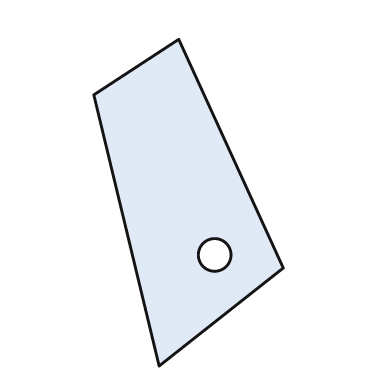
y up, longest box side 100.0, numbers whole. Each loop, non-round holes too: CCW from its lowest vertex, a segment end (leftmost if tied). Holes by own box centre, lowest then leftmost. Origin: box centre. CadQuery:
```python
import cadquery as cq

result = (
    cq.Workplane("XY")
    .moveTo(-9.0, -50.0)
    .lineTo(29.0, -20.0)
    .lineTo(-3.0, 50.0)
    .lineTo(-29.0, 33.0)
    .close()
    .moveTo(8.0, -16.0)
    .circle(5.0)
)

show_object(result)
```